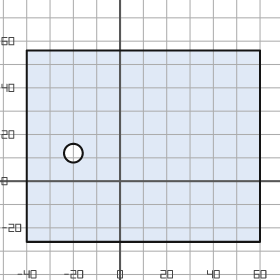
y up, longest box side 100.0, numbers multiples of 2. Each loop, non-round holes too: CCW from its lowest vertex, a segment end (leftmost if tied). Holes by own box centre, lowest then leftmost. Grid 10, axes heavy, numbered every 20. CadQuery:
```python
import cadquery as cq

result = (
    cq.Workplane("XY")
    .moveTo(-40.0, -26.0)
    .lineTo(60.0, -26.0)
    .lineTo(60.0, 56.0)
    .lineTo(-40.0, 56.0)
    .close()
    .moveTo(-20.0, 12.0)
    .circle(4.0)
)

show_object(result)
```